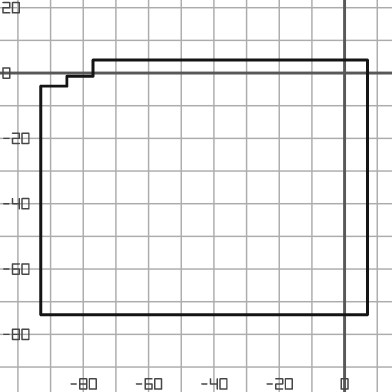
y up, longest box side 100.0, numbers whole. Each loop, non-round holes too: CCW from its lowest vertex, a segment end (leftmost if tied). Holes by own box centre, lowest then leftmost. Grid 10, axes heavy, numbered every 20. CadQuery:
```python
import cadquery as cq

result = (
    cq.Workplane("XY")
    .moveTo(-93.0, -74.0)
    .lineTo(7.0, -74.0)
    .lineTo(7.0, 4.0)
    .lineTo(-77.0, 4.0)
    .lineTo(-77.0, -1.0)
    .lineTo(-85.0, -1.0)
    .lineTo(-85.0, -4.0)
    .lineTo(-93.0, -4.0)
    .close()
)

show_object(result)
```